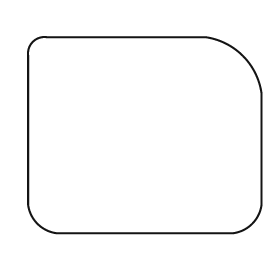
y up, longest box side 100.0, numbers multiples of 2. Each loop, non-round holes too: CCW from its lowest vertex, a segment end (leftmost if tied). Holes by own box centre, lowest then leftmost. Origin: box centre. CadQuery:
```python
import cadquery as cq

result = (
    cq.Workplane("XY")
    .moveTo(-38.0, -42.0)
    .lineTo(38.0, -42.0)
    .threePointArc((46.0, -38.0), (50.0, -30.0))
    .lineTo(50.0, 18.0)
    .threePointArc((42.0, 34.0), (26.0, 42.0))
    .lineTo(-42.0, 42.0)
    .threePointArc((-48.0, 40.0), (-50.0, 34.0))
    .lineTo(-50.0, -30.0)
    .threePointArc((-46.0, -38.0), (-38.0, -42.0))
    .close()
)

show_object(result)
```